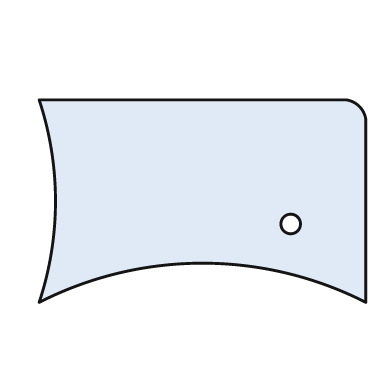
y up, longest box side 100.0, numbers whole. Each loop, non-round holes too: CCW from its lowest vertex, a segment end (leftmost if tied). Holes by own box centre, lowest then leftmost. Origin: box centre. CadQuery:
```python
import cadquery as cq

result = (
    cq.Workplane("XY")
    .moveTo(-50.0, -31.0)
    .threePointArc((0.0, -19.0), (50.0, -31.0))
    .lineTo(50.0, 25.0)
    .threePointArc((48.0, 29.0), (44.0, 31.0))
    .lineTo(-50.0, 31.0)
    .threePointArc((-45.0, 0.0), (-50.0, -31.0))
    .close()
    .moveTo(27.0, -7.0)
    .circle(3.0)
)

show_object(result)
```